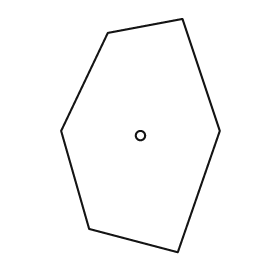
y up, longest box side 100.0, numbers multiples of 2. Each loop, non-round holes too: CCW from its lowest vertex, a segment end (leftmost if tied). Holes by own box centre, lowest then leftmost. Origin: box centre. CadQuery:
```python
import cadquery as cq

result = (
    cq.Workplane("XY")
    .moveTo(16.0, -50.0)
    .lineTo(34.0, 2.0)
    .lineTo(18.0, 50.0)
    .lineTo(-14.0, 44.0)
    .lineTo(-34.0, 2.0)
    .lineTo(-22.0, -40.0)
    .close()
    .moveTo(0.0, 0.0)
    .circle(2.0)
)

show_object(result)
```